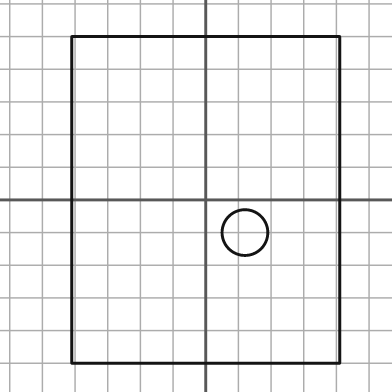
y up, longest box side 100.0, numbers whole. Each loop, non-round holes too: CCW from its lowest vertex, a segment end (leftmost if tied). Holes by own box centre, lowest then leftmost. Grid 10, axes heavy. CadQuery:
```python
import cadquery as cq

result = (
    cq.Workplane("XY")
    .moveTo(-41.0, -50.0)
    .lineTo(41.0, -50.0)
    .lineTo(41.0, 50.0)
    .lineTo(-41.0, 50.0)
    .close()
    .moveTo(12.0, -10.0)
    .circle(7.0)
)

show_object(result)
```